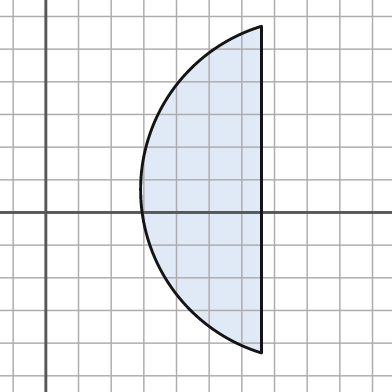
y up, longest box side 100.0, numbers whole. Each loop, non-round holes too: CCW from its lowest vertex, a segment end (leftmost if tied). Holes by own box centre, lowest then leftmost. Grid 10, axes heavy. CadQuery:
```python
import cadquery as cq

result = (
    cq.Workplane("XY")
    .moveTo(66.0, -43.0)
    .lineTo(66.0, 57.0)
    .threePointArc((29.0, 7.0), (66.0, -43.0))
    .close()
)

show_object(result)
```